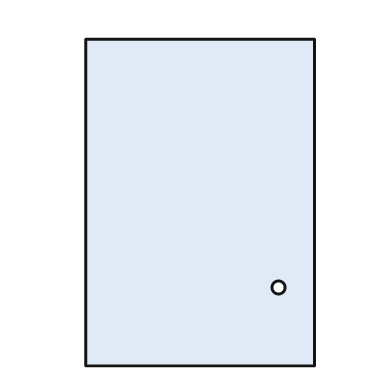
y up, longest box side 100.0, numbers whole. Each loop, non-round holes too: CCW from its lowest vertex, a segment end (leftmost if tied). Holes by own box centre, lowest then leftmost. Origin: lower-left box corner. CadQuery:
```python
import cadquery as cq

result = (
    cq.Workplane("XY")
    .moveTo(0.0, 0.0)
    .lineTo(70.0, 0.0)
    .lineTo(70.0, 100.0)
    .lineTo(0.0, 100.0)
    .close()
    .moveTo(59.0, 24.0)
    .circle(2.0)
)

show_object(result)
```